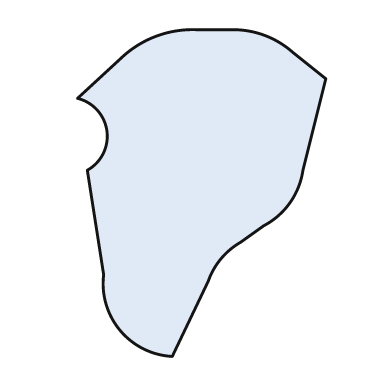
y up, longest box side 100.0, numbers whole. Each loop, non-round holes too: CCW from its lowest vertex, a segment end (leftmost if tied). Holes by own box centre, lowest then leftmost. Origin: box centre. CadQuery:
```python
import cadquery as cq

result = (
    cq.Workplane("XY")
    .moveTo(-9.0, -50.0)
    .lineTo(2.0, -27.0)
    .threePointArc((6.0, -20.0), (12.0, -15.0))
    .lineTo(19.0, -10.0)
    .threePointArc((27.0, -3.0), (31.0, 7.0))
    .lineTo(38.0, 35.0)
    .lineTo(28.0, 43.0)
    .threePointArc((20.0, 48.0), (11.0, 50.0))
    .lineTo(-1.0, 50.0)
    .threePointArc((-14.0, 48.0), (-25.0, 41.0))
    .lineTo(-38.0, 29.0)
    .threePointArc((-29.0, 19.0), (-35.0, 7.0))
    .lineTo(-30.0, -25.0)
    .threePointArc((-25.0, -42.0), (-9.0, -50.0))
    .close()
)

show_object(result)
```